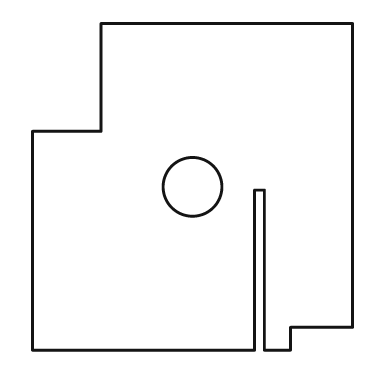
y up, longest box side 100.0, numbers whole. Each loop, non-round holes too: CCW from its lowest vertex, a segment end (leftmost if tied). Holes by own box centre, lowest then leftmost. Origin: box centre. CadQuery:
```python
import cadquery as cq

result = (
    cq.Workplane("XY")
    .moveTo(-49.0, -50.0)
    .lineTo(19.0, -50.0)
    .lineTo(19.0, -1.0)
    .lineTo(22.0, -1.0)
    .lineTo(22.0, -50.0)
    .lineTo(30.0, -50.0)
    .lineTo(30.0, -43.0)
    .lineTo(49.0, -43.0)
    .lineTo(49.0, 50.0)
    .lineTo(-28.0, 50.0)
    .lineTo(-28.0, 17.0)
    .lineTo(-49.0, 17.0)
    .close()
    .moveTo(0.0, 0.0)
    .circle(9.0)
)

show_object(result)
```